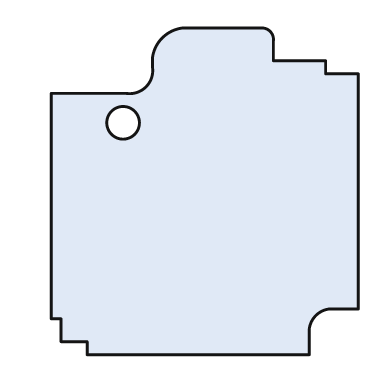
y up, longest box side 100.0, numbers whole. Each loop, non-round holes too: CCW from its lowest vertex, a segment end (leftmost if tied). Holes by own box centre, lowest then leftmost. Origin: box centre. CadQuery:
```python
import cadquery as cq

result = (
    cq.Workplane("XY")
    .moveTo(-36.0, -50.0)
    .lineTo(32.0, -50.0)
    .lineTo(32.0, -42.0)
    .threePointArc((34.0, -38.0), (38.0, -36.0))
    .lineTo(47.0, -36.0)
    .lineTo(47.0, 36.0)
    .lineTo(37.0, 36.0)
    .lineTo(37.0, 40.0)
    .lineTo(21.0, 40.0)
    .lineTo(21.0, 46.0)
    .threePointArc((20.0, 49.0), (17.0, 50.0))
    .lineTo(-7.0, 50.0)
    .threePointArc((-13.0, 47.0), (-16.0, 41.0))
    .lineTo(-16.0, 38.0)
    .threePointArc((-18.0, 32.0), (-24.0, 30.0))
    .lineTo(-47.0, 30.0)
    .lineTo(-47.0, -39.0)
    .lineTo(-44.0, -39.0)
    .lineTo(-44.0, -46.0)
    .lineTo(-36.0, -46.0)
    .close()
    .moveTo(-25.0, 21.0)
    .circle(5.0)
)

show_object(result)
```